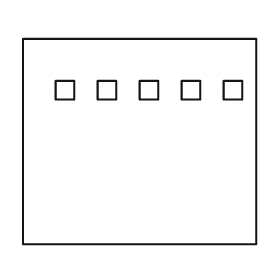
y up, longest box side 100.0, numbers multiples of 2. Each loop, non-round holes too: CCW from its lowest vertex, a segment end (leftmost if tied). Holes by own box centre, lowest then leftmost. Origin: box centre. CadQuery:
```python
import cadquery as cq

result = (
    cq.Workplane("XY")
    .moveTo(-50.0, -44.0)
    .lineTo(50.0, -44.0)
    .lineTo(50.0, 44.0)
    .lineTo(-50.0, 44.0)
    .close()
    .moveTo(-36.0, 18.0)
    .lineTo(-28.0, 18.0)
    .lineTo(-28.0, 26.0)
    .lineTo(-36.0, 26.0)
    .close()
    .moveTo(-18.0, 18.0)
    .lineTo(-10.0, 18.0)
    .lineTo(-10.0, 26.0)
    .lineTo(-18.0, 26.0)
    .close()
    .moveTo(0.0, 18.0)
    .lineTo(8.0, 18.0)
    .lineTo(8.0, 26.0)
    .lineTo(0.0, 26.0)
    .close()
    .moveTo(18.0, 18.0)
    .lineTo(26.0, 18.0)
    .lineTo(26.0, 26.0)
    .lineTo(18.0, 26.0)
    .close()
    .moveTo(36.0, 18.0)
    .lineTo(44.0, 18.0)
    .lineTo(44.0, 26.0)
    .lineTo(36.0, 26.0)
    .close()
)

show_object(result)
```